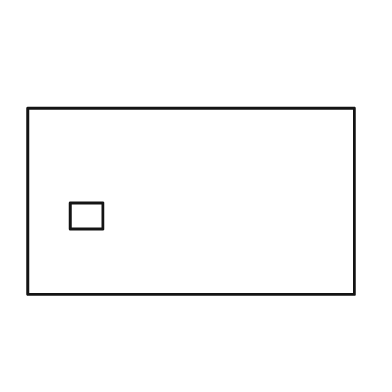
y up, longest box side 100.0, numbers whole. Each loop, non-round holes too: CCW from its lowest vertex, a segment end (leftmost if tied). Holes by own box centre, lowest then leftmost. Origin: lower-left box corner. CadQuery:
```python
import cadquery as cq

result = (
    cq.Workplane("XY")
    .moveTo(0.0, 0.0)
    .lineTo(100.0, 0.0)
    .lineTo(100.0, 57.0)
    .lineTo(0.0, 57.0)
    .close()
    .moveTo(13.0, 20.0)
    .lineTo(23.0, 20.0)
    .lineTo(23.0, 28.0)
    .lineTo(13.0, 28.0)
    .close()
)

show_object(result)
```